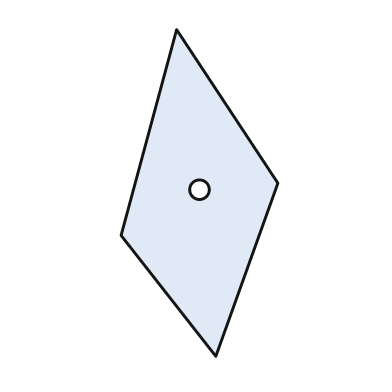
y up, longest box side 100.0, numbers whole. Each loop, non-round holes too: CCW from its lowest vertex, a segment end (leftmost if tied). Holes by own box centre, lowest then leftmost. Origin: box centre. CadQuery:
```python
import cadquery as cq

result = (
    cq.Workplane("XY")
    .moveTo(5.0, -50.0)
    .lineTo(24.0, 3.0)
    .lineTo(-7.0, 50.0)
    .lineTo(-24.0, -13.0)
    .close()
    .moveTo(0.0, 1.0)
    .circle(3.0)
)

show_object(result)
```